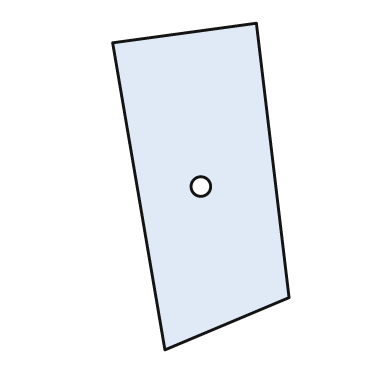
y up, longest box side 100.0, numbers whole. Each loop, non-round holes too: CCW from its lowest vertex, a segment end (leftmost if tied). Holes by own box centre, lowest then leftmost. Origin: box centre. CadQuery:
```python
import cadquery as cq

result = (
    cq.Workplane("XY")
    .moveTo(-11.0, -50.0)
    .lineTo(27.0, -34.0)
    .lineTo(17.0, 50.0)
    .lineTo(-27.0, 44.0)
    .close()
    .moveTo(0.0, 0.0)
    .circle(3.0)
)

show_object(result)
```